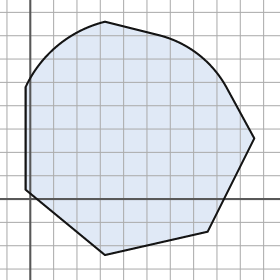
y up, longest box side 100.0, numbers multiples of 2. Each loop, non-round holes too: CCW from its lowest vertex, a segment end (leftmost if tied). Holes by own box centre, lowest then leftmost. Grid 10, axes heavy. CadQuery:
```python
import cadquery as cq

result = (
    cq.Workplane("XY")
    .moveTo(32.0, -24.0)
    .lineTo(76.0, -14.0)
    .lineTo(96.0, 26.0)
    .lineTo(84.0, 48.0)
    .threePointArc((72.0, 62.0), (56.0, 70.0))
    .lineTo(32.0, 76.0)
    .threePointArc((12.0, 66.0), (-2.0, 48.0))
    .lineTo(-2.0, 4.0)
    .close()
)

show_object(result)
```